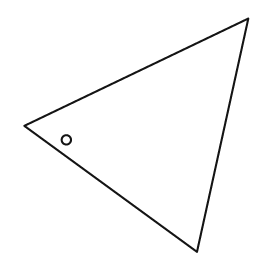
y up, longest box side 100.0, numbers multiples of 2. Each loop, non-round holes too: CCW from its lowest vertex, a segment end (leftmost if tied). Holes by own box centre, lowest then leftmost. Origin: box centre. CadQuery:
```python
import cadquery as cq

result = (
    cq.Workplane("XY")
    .moveTo(26.0, -50.0)
    .lineTo(48.0, 50.0)
    .lineTo(-48.0, 4.0)
    .close()
    .moveTo(-30.0, -2.0)
    .circle(2.0)
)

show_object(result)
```